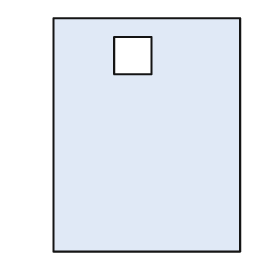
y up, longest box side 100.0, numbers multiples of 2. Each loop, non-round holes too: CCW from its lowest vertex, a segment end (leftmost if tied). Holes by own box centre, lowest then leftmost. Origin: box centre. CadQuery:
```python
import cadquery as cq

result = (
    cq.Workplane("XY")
    .moveTo(-40.0, -50.0)
    .lineTo(40.0, -50.0)
    .lineTo(40.0, 50.0)
    .lineTo(-40.0, 50.0)
    .close()
    .moveTo(-14.0, 26.0)
    .lineTo(2.0, 26.0)
    .lineTo(2.0, 42.0)
    .lineTo(-14.0, 42.0)
    .close()
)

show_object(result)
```